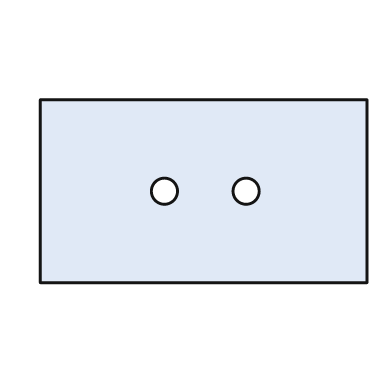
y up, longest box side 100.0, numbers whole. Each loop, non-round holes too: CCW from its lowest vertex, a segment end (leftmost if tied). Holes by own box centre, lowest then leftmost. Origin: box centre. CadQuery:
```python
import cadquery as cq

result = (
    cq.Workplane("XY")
    .moveTo(-50.0, -28.0)
    .lineTo(50.0, -28.0)
    .lineTo(50.0, 28.0)
    .lineTo(-50.0, 28.0)
    .close()
    .moveTo(-12.0, 0.0)
    .circle(4.0)
    .moveTo(13.0, 0.0)
    .circle(4.0)
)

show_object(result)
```